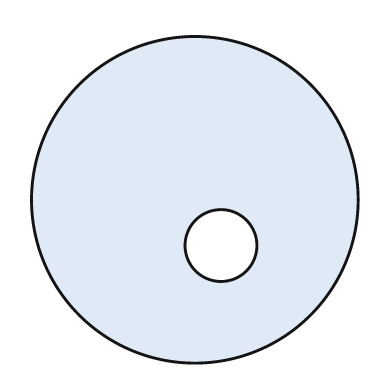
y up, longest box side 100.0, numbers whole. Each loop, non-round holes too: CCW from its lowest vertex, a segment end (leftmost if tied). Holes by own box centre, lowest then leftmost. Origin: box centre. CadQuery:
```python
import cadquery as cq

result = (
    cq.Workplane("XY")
    .moveTo(0.0, 0.0)
    .circle(50.0)
    .moveTo(8.0, -14.0)
    .circle(11.0)
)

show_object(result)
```